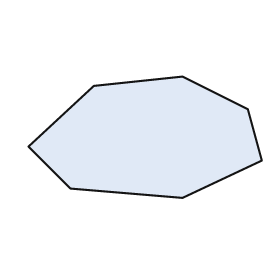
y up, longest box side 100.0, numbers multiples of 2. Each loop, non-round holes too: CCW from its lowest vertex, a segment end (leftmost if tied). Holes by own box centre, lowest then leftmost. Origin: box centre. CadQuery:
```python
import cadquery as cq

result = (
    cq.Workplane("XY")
    .moveTo(16.0, -26.0)
    .lineTo(50.0, -10.0)
    .lineTo(44.0, 12.0)
    .lineTo(16.0, 26.0)
    .lineTo(-22.0, 22.0)
    .lineTo(-50.0, -4.0)
    .lineTo(-32.0, -22.0)
    .close()
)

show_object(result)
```